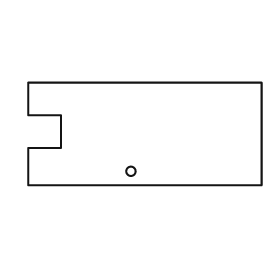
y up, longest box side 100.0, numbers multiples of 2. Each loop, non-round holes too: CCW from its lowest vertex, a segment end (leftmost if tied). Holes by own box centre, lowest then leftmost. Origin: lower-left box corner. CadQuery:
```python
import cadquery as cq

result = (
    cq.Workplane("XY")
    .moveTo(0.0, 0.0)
    .lineTo(100.0, 0.0)
    .lineTo(100.0, 44.0)
    .lineTo(0.0, 44.0)
    .lineTo(0.0, 30.0)
    .lineTo(14.0, 30.0)
    .lineTo(14.0, 16.0)
    .lineTo(0.0, 16.0)
    .close()
    .moveTo(44.0, 6.0)
    .circle(2.0)
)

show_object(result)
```